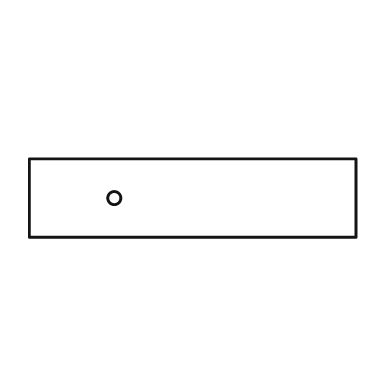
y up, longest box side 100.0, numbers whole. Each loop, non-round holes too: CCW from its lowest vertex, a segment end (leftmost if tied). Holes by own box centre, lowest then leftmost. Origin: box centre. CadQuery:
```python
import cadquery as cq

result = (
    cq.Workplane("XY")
    .moveTo(-50.0, -12.0)
    .lineTo(50.0, -12.0)
    .lineTo(50.0, 12.0)
    .lineTo(-50.0, 12.0)
    .close()
    .moveTo(-24.0, 0.0)
    .circle(2.0)
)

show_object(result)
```